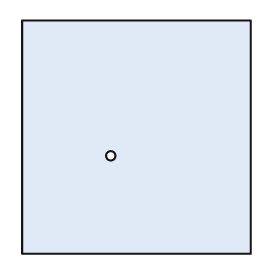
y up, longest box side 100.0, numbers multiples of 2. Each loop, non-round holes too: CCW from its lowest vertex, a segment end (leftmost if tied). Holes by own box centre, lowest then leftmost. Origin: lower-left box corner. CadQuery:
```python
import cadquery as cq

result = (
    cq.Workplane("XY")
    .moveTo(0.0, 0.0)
    .lineTo(98.0, 0.0)
    .lineTo(98.0, 100.0)
    .lineTo(0.0, 100.0)
    .close()
    .moveTo(38.0, 42.0)
    .circle(2.0)
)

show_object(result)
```